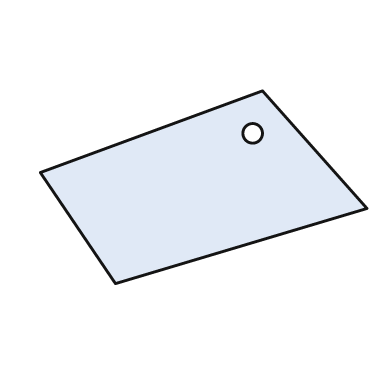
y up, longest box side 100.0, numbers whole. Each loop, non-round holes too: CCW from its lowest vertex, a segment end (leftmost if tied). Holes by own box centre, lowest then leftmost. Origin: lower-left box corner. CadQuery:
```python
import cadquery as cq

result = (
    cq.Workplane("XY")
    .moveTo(23.0, 0.0)
    .lineTo(100.0, 23.0)
    .lineTo(68.0, 59.0)
    .lineTo(0.0, 34.0)
    .close()
    .moveTo(65.0, 46.0)
    .circle(3.0)
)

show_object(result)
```